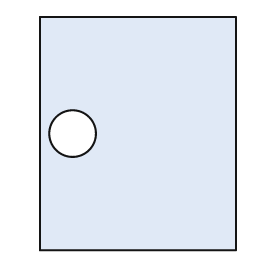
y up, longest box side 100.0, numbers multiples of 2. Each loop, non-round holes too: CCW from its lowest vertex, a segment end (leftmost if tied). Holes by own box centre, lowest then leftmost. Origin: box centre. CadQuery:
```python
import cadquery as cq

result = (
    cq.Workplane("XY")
    .moveTo(-42.0, -50.0)
    .lineTo(42.0, -50.0)
    .lineTo(42.0, 50.0)
    .lineTo(-42.0, 50.0)
    .close()
    .moveTo(-28.0, 0.0)
    .circle(10.0)
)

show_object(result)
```